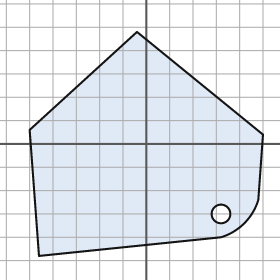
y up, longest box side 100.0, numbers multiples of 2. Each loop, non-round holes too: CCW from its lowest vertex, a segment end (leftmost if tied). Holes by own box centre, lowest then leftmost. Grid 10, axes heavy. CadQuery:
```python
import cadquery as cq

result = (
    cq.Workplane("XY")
    .moveTo(-46.0, -48.0)
    .lineTo(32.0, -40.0)
    .threePointArc((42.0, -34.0), (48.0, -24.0))
    .lineTo(50.0, 4.0)
    .lineTo(-4.0, 48.0)
    .lineTo(-50.0, 6.0)
    .close()
    .moveTo(32.0, -30.0)
    .circle(4.0)
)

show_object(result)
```